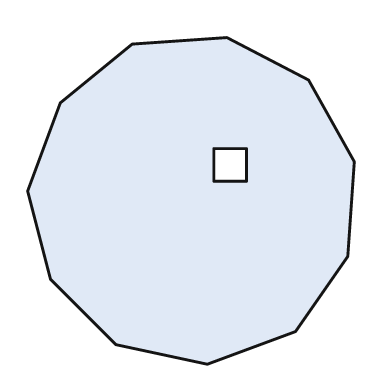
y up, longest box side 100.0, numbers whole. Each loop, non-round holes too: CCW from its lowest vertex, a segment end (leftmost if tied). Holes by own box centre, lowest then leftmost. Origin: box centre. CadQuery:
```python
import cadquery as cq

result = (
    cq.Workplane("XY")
    .moveTo(5.0, -50.0)
    .lineTo(32.0, -40.0)
    .lineTo(48.0, -17.0)
    .lineTo(50.0, 12.0)
    .lineTo(36.0, 37.0)
    .lineTo(11.0, 50.0)
    .lineTo(-18.0, 48.0)
    .lineTo(-40.0, 30.0)
    .lineTo(-50.0, 3.0)
    .lineTo(-43.0, -24.0)
    .lineTo(-23.0, -44.0)
    .close()
    .moveTo(7.0, 6.0)
    .lineTo(17.0, 6.0)
    .lineTo(17.0, 16.0)
    .lineTo(7.0, 16.0)
    .close()
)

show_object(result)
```